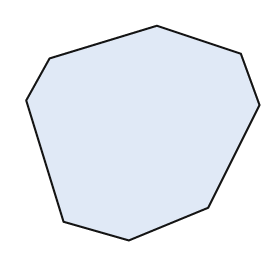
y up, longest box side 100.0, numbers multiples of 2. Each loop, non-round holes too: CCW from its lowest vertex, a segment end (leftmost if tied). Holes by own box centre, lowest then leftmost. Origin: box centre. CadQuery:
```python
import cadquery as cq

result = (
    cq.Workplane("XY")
    .moveTo(-6.0, -46.0)
    .lineTo(28.0, -32.0)
    .lineTo(50.0, 12.0)
    .lineTo(42.0, 34.0)
    .lineTo(6.0, 46.0)
    .lineTo(-40.0, 32.0)
    .lineTo(-50.0, 14.0)
    .lineTo(-34.0, -38.0)
    .close()
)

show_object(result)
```